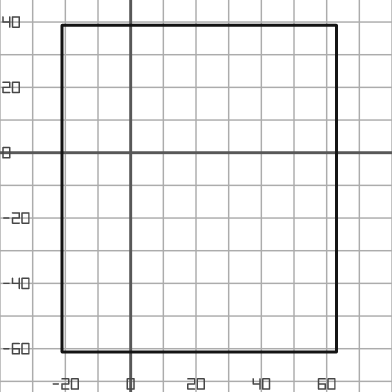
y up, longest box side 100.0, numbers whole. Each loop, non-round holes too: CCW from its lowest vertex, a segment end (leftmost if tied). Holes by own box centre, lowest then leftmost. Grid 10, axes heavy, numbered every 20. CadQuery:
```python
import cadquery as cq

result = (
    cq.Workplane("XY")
    .moveTo(-21.0, -61.0)
    .lineTo(63.0, -61.0)
    .lineTo(63.0, 39.0)
    .lineTo(-21.0, 39.0)
    .close()
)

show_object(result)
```